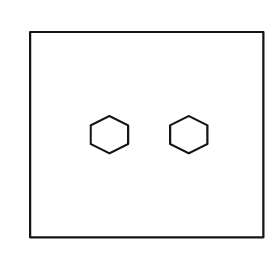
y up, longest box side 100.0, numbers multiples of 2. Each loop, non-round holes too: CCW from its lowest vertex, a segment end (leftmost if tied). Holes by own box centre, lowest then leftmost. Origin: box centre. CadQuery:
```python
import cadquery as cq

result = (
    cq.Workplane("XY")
    .moveTo(-50.0, -44.0)
    .lineTo(50.0, -44.0)
    .lineTo(50.0, 44.0)
    .lineTo(-50.0, 44.0)
    .close()
    .moveTo(-16.0, -8.0)
    .lineTo(-8.0, -4.0)
    .lineTo(-8.0, 4.0)
    .lineTo(-16.0, 8.0)
    .lineTo(-24.0, 4.0)
    .lineTo(-24.0, -4.0)
    .close()
    .moveTo(18.0, -8.0)
    .lineTo(26.0, -4.0)
    .lineTo(26.0, 4.0)
    .lineTo(18.0, 8.0)
    .lineTo(10.0, 4.0)
    .lineTo(10.0, -4.0)
    .close()
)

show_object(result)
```